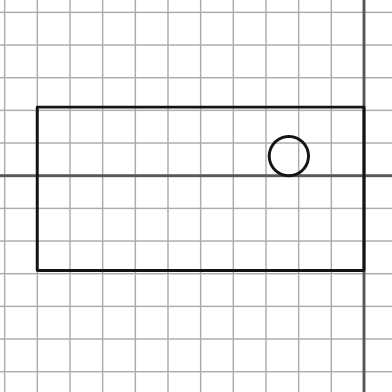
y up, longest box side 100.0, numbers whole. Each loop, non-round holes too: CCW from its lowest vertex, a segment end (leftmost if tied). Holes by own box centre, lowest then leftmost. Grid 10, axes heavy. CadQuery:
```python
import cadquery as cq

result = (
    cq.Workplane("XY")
    .moveTo(-100.0, -29.0)
    .lineTo(0.0, -29.0)
    .lineTo(0.0, 21.0)
    .lineTo(-100.0, 21.0)
    .close()
    .moveTo(-23.0, 6.0)
    .circle(6.0)
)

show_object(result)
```